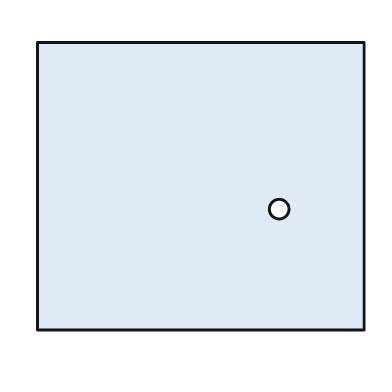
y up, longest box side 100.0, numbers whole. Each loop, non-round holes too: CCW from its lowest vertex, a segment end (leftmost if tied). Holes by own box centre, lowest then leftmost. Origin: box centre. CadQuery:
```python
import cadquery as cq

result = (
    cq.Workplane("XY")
    .moveTo(-50.0, -44.0)
    .lineTo(50.0, -44.0)
    .lineTo(50.0, 44.0)
    .lineTo(-50.0, 44.0)
    .close()
    .moveTo(24.0, -7.0)
    .circle(3.0)
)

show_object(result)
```